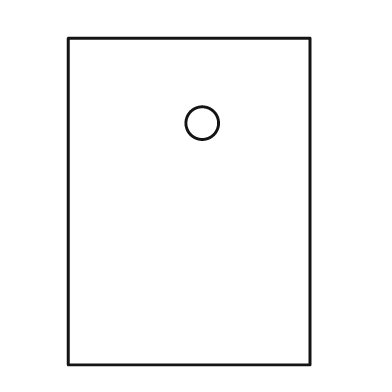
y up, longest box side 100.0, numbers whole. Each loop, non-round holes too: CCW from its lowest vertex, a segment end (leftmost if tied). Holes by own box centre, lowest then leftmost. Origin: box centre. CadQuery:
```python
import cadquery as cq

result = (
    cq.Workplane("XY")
    .moveTo(-37.0, -50.0)
    .lineTo(37.0, -50.0)
    .lineTo(37.0, 50.0)
    .lineTo(-37.0, 50.0)
    .close()
    .moveTo(4.0, 24.0)
    .circle(5.0)
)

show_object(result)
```